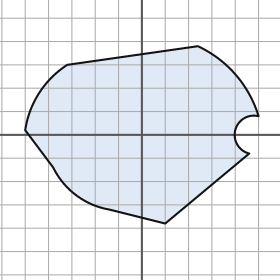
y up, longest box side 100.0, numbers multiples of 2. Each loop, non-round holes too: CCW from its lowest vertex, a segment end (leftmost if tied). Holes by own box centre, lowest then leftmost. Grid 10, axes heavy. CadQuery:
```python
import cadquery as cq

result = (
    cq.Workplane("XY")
    .moveTo(10.0, -38.0)
    .lineTo(46.0, -8.0)
    .threePointArc((40.0, 2.0), (50.0, 8.0))
    .threePointArc((40.0, 26.0), (24.0, 38.0))
    .lineTo(-32.0, 30.0)
    .threePointArc((-44.0, 18.0), (-50.0, 2.0))
    .lineTo(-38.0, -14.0)
    .threePointArc((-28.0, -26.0), (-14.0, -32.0))
    .close()
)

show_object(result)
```